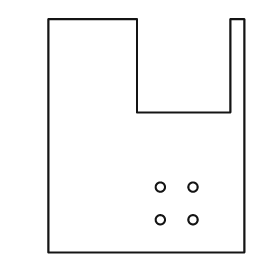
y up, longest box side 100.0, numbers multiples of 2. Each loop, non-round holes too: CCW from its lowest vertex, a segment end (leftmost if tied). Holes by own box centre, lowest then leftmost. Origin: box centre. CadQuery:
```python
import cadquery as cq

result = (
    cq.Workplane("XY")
    .moveTo(-42.0, -50.0)
    .lineTo(42.0, -50.0)
    .lineTo(42.0, 50.0)
    .lineTo(36.0, 50.0)
    .lineTo(36.0, 10.0)
    .lineTo(-4.0, 10.0)
    .lineTo(-4.0, 50.0)
    .lineTo(-42.0, 50.0)
    .close()
    .moveTo(6.0, -36.0)
    .circle(2.0)
    .moveTo(20.0, -36.0)
    .circle(2.0)
    .moveTo(6.0, -22.0)
    .circle(2.0)
    .moveTo(20.0, -22.0)
    .circle(2.0)
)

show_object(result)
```